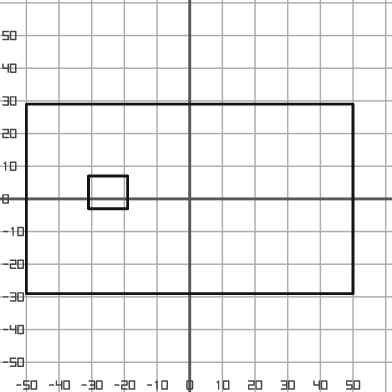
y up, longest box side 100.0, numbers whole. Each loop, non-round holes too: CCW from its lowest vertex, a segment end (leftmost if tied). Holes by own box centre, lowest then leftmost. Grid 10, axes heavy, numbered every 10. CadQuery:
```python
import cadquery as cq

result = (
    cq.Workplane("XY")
    .moveTo(-50.0, -29.0)
    .lineTo(50.0, -29.0)
    .lineTo(50.0, 29.0)
    .lineTo(-50.0, 29.0)
    .close()
    .moveTo(-31.0, -3.0)
    .lineTo(-19.0, -3.0)
    .lineTo(-19.0, 7.0)
    .lineTo(-31.0, 7.0)
    .close()
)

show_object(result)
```